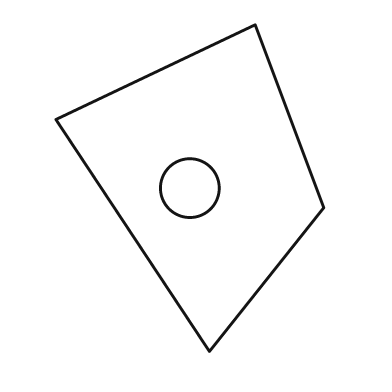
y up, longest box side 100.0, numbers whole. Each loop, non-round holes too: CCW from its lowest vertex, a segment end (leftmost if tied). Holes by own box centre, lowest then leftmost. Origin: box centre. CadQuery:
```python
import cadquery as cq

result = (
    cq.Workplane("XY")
    .moveTo(6.0, -50.0)
    .lineTo(41.0, -6.0)
    .lineTo(20.0, 50.0)
    .lineTo(-41.0, 21.0)
    .close()
    .moveTo(0.0, 0.0)
    .circle(9.0)
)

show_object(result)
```